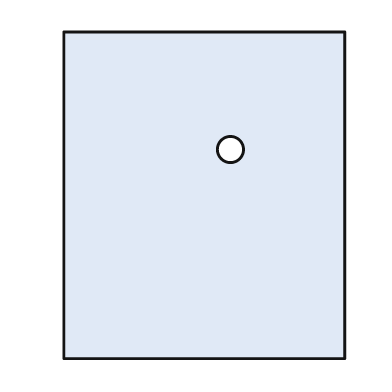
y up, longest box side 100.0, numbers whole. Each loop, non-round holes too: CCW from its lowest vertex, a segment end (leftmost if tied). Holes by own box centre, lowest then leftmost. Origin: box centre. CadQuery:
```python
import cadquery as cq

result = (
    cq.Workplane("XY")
    .moveTo(-43.0, -50.0)
    .lineTo(43.0, -50.0)
    .lineTo(43.0, 50.0)
    .lineTo(-43.0, 50.0)
    .close()
    .moveTo(8.0, 14.0)
    .circle(4.0)
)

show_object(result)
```